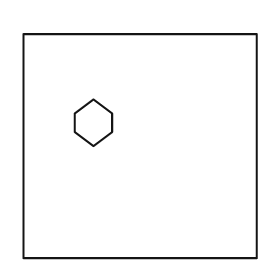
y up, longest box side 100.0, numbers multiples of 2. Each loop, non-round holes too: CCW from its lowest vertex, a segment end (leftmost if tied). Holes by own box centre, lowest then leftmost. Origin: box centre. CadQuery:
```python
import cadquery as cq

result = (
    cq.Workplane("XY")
    .moveTo(-50.0, -48.0)
    .lineTo(50.0, -48.0)
    .lineTo(50.0, 48.0)
    .lineTo(-50.0, 48.0)
    .close()
    .moveTo(-20.0, 0.0)
    .lineTo(-12.0, 6.0)
    .lineTo(-12.0, 14.0)
    .lineTo(-20.0, 20.0)
    .lineTo(-28.0, 14.0)
    .lineTo(-28.0, 6.0)
    .close()
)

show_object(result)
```